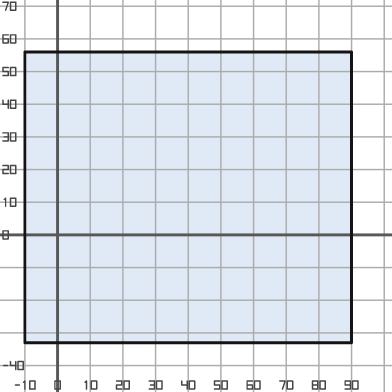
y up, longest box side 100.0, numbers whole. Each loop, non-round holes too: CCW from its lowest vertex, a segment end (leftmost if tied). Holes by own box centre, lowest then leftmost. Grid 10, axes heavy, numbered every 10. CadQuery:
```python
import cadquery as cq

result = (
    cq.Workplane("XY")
    .moveTo(-10.0, -33.0)
    .lineTo(90.0, -33.0)
    .lineTo(90.0, 56.0)
    .lineTo(-10.0, 56.0)
    .close()
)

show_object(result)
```